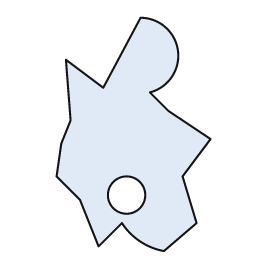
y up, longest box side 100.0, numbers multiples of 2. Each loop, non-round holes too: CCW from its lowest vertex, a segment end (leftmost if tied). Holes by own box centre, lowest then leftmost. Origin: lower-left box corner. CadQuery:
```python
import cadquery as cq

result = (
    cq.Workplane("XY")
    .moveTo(46.0, 0.0)
    .lineTo(60.0, 12.0)
    .lineTo(54.0, 32.0)
    .lineTo(66.0, 48.0)
    .lineTo(48.0, 60.0)
    .lineTo(40.0, 68.0)
    .threePointArc((52.0, 86.0), (36.0, 100.0))
    .lineTo(20.0, 70.0)
    .lineTo(4.0, 82.0)
    .lineTo(6.0, 56.0)
    .lineTo(2.0, 46.0)
    .lineTo(0.0, 32.0)
    .lineTo(10.0, 22.0)
    .lineTo(18.0, 2.0)
    .lineTo(28.0, 12.0)
    .threePointArc((36.0, 4.0), (46.0, 0.0))
    .close()
    .moveTo(30.0, 24.0)
    .circle(8.0)
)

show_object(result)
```